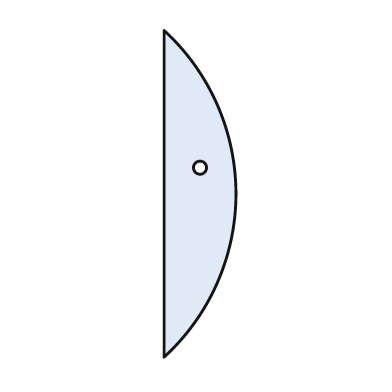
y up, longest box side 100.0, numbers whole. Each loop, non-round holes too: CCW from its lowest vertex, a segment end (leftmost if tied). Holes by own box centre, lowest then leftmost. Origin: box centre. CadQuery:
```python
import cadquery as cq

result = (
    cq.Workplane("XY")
    .moveTo(-11.0, -50.0)
    .threePointArc((11.0, 0.0), (-11.0, 50.0))
    .close()
    .moveTo(0.0, 8.0)
    .circle(2.0)
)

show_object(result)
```